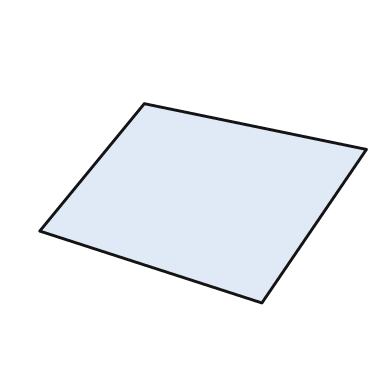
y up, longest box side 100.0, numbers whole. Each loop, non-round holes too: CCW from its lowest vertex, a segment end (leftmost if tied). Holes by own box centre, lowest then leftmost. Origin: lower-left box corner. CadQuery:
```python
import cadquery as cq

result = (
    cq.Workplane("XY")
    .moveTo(68.0, 0.0)
    .lineTo(100.0, 47.0)
    .lineTo(32.0, 61.0)
    .lineTo(0.0, 22.0)
    .close()
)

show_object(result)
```